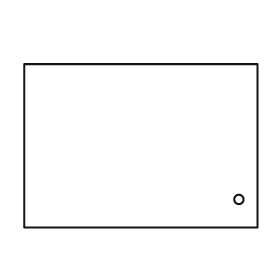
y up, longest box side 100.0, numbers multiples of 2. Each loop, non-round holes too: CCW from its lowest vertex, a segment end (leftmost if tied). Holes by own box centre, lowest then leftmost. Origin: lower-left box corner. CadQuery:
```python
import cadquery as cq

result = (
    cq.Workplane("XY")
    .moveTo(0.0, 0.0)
    .lineTo(100.0, 0.0)
    .lineTo(100.0, 70.0)
    .lineTo(0.0, 70.0)
    .close()
    .moveTo(92.0, 12.0)
    .circle(2.0)
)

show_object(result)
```